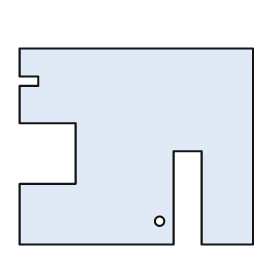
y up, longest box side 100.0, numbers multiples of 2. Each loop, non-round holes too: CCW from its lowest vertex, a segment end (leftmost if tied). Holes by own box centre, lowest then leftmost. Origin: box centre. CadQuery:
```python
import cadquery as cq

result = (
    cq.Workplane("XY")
    .moveTo(-50.0, -42.0)
    .lineTo(16.0, -42.0)
    .lineTo(16.0, -2.0)
    .lineTo(28.0, -2.0)
    .lineTo(28.0, -42.0)
    .lineTo(50.0, -42.0)
    .lineTo(50.0, 42.0)
    .lineTo(-50.0, 42.0)
    .lineTo(-50.0, 30.0)
    .lineTo(-42.0, 30.0)
    .lineTo(-42.0, 26.0)
    .lineTo(-50.0, 26.0)
    .lineTo(-50.0, 10.0)
    .lineTo(-26.0, 10.0)
    .lineTo(-26.0, -16.0)
    .lineTo(-50.0, -16.0)
    .close()
    .moveTo(10.0, -32.0)
    .circle(2.0)
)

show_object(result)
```